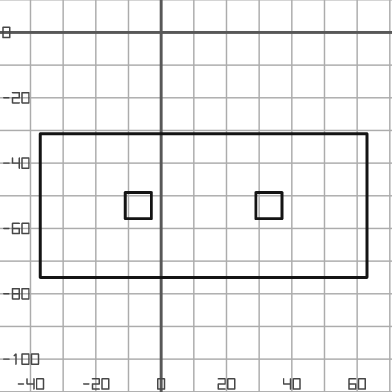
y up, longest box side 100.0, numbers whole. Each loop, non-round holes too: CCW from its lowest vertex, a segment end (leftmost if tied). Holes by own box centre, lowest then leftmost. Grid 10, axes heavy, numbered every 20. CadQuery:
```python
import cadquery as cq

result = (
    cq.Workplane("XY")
    .moveTo(-37.0, -75.0)
    .lineTo(63.0, -75.0)
    .lineTo(63.0, -31.0)
    .lineTo(-37.0, -31.0)
    .close()
    .moveTo(-11.0, -57.0)
    .lineTo(-3.0, -57.0)
    .lineTo(-3.0, -49.0)
    .lineTo(-11.0, -49.0)
    .close()
    .moveTo(29.0, -57.0)
    .lineTo(37.0, -57.0)
    .lineTo(37.0, -49.0)
    .lineTo(29.0, -49.0)
    .close()
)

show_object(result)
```